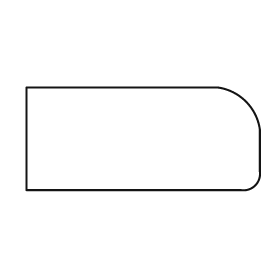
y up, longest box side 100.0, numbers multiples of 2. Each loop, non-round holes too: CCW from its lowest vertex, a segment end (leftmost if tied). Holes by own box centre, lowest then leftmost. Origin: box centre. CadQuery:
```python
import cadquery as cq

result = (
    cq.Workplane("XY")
    .moveTo(-50.0, -22.0)
    .lineTo(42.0, -22.0)
    .threePointArc((48.0, -20.0), (50.0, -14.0))
    .lineTo(50.0, 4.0)
    .threePointArc((44.0, 16.0), (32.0, 22.0))
    .lineTo(-50.0, 22.0)
    .close()
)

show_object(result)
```